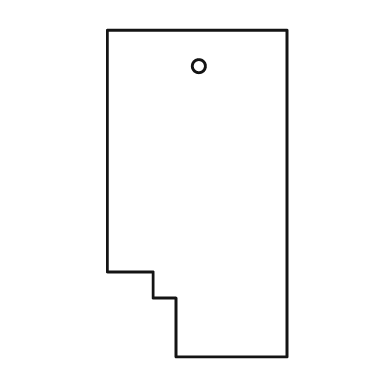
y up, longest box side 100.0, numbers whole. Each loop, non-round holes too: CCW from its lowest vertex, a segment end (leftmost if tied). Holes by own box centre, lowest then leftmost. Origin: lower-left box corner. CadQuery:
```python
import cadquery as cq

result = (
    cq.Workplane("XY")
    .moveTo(21.0, 0.0)
    .lineTo(55.0, 0.0)
    .lineTo(55.0, 100.0)
    .lineTo(0.0, 100.0)
    .lineTo(0.0, 26.0)
    .lineTo(14.0, 26.0)
    .lineTo(14.0, 18.0)
    .lineTo(21.0, 18.0)
    .close()
    .moveTo(28.0, 89.0)
    .circle(2.0)
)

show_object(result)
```